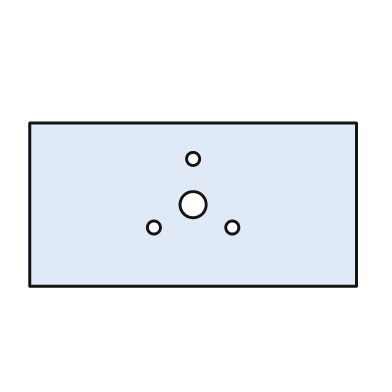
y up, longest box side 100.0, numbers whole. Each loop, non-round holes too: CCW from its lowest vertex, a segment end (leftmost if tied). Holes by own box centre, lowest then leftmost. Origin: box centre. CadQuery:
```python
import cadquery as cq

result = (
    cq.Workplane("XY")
    .moveTo(-50.0, -25.0)
    .lineTo(50.0, -25.0)
    .lineTo(50.0, 25.0)
    .lineTo(-50.0, 25.0)
    .close()
    .moveTo(-12.0, -7.0)
    .circle(2.0)
    .moveTo(12.0, -7.0)
    .circle(2.0)
    .moveTo(0.0, 0.0)
    .circle(4.0)
    .moveTo(0.0, 14.0)
    .circle(2.0)
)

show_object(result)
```